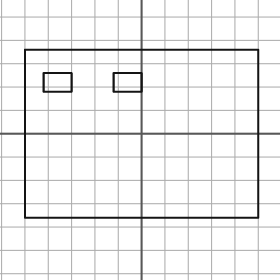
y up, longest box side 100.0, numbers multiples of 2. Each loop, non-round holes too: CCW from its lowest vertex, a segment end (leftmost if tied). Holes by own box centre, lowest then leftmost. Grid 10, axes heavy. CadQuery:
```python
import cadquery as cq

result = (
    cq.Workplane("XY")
    .moveTo(-50.0, -36.0)
    .lineTo(50.0, -36.0)
    .lineTo(50.0, 36.0)
    .lineTo(-50.0, 36.0)
    .close()
    .moveTo(-42.0, 18.0)
    .lineTo(-30.0, 18.0)
    .lineTo(-30.0, 26.0)
    .lineTo(-42.0, 26.0)
    .close()
    .moveTo(-12.0, 18.0)
    .lineTo(0.0, 18.0)
    .lineTo(0.0, 26.0)
    .lineTo(-12.0, 26.0)
    .close()
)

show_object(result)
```